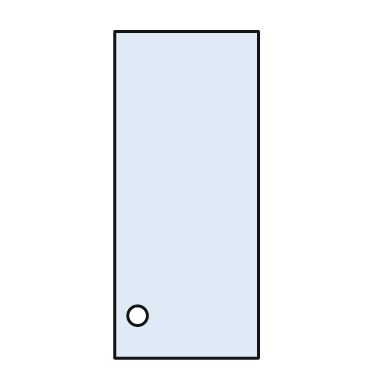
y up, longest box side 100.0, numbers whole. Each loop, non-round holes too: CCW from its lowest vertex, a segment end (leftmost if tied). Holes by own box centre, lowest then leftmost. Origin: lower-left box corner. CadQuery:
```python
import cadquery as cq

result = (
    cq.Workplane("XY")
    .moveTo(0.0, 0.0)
    .lineTo(44.0, 0.0)
    .lineTo(44.0, 100.0)
    .lineTo(0.0, 100.0)
    .close()
    .moveTo(7.0, 13.0)
    .circle(3.0)
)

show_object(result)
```